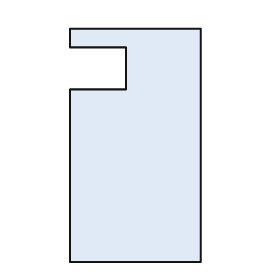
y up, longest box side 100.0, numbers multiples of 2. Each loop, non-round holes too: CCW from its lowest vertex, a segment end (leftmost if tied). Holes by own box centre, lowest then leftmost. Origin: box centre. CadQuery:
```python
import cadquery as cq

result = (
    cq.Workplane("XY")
    .moveTo(-28.0, -50.0)
    .lineTo(28.0, -50.0)
    .lineTo(28.0, 50.0)
    .lineTo(-28.0, 50.0)
    .lineTo(-28.0, 42.0)
    .lineTo(-4.0, 42.0)
    .lineTo(-4.0, 24.0)
    .lineTo(-28.0, 24.0)
    .close()
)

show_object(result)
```